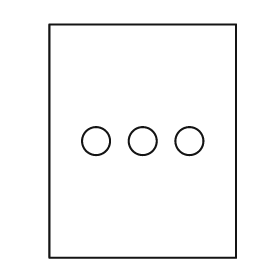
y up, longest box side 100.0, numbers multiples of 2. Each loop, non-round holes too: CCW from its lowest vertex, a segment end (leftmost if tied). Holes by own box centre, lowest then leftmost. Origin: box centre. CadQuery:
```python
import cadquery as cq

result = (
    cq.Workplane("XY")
    .moveTo(-40.0, -50.0)
    .lineTo(40.0, -50.0)
    .lineTo(40.0, 50.0)
    .lineTo(-40.0, 50.0)
    .close()
    .moveTo(-20.0, 0.0)
    .circle(6.0)
    .moveTo(0.0, 0.0)
    .circle(6.0)
    .moveTo(20.0, 0.0)
    .circle(6.0)
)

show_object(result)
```